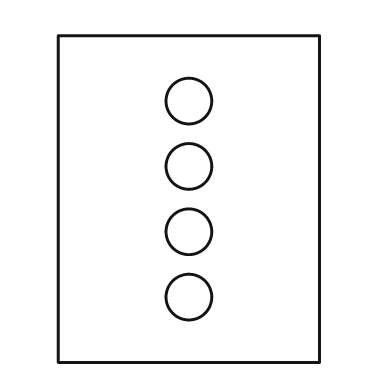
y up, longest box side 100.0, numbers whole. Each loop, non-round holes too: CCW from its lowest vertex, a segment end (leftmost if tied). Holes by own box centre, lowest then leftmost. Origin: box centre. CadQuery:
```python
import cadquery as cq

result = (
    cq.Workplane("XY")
    .moveTo(-40.0, -50.0)
    .lineTo(40.0, -50.0)
    .lineTo(40.0, 50.0)
    .lineTo(-40.0, 50.0)
    .close()
    .moveTo(0.0, -30.0)
    .circle(7.0)
    .moveTo(0.0, -10.0)
    .circle(7.0)
    .moveTo(0.0, 10.0)
    .circle(7.0)
    .moveTo(0.0, 30.0)
    .circle(7.0)
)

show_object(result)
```